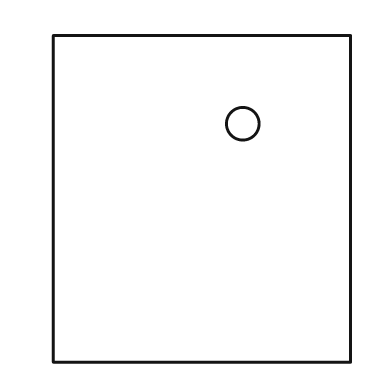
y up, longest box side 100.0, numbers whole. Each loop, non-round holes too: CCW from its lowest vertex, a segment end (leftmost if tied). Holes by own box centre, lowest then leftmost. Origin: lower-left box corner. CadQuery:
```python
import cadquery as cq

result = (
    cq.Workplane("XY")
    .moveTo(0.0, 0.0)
    .lineTo(91.0, 0.0)
    .lineTo(91.0, 100.0)
    .lineTo(0.0, 100.0)
    .close()
    .moveTo(58.0, 73.0)
    .circle(5.0)
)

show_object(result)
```